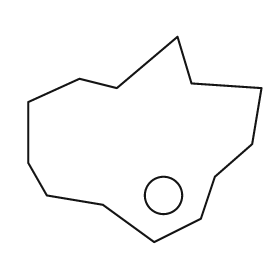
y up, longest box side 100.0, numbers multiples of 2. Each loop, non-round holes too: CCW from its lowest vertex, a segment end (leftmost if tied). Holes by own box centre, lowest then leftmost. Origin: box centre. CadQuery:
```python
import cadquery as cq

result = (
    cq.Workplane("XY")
    .moveTo(4.0, -44.0)
    .lineTo(24.0, -34.0)
    .lineTo(30.0, -16.0)
    .lineTo(46.0, -2.0)
    .lineTo(50.0, 22.0)
    .lineTo(20.0, 24.0)
    .lineTo(14.0, 44.0)
    .lineTo(-12.0, 22.0)
    .lineTo(-28.0, 26.0)
    .lineTo(-50.0, 16.0)
    .lineTo(-50.0, -10.0)
    .lineTo(-42.0, -24.0)
    .lineTo(-18.0, -28.0)
    .close()
    .moveTo(8.0, -24.0)
    .circle(8.0)
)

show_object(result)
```